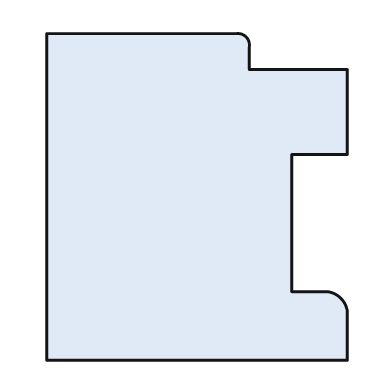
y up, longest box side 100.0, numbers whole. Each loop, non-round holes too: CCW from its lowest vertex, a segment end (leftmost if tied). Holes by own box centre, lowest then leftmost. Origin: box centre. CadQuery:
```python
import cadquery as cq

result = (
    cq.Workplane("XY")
    .moveTo(-46.0, -50.0)
    .lineTo(46.0, -50.0)
    .lineTo(46.0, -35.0)
    .threePointArc((44.0, -31.0), (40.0, -29.0))
    .lineTo(29.0, -29.0)
    .lineTo(29.0, 13.0)
    .lineTo(46.0, 13.0)
    .lineTo(46.0, 39.0)
    .lineTo(16.0, 39.0)
    .lineTo(16.0, 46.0)
    .threePointArc((15.0, 49.0), (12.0, 50.0))
    .lineTo(-46.0, 50.0)
    .close()
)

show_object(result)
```